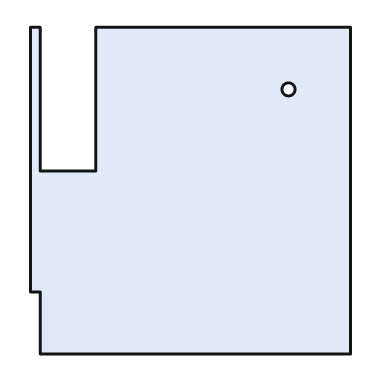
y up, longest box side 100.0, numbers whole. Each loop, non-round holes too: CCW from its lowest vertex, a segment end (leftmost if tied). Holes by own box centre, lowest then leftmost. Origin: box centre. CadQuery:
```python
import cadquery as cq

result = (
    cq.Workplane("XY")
    .moveTo(-46.0, -50.0)
    .lineTo(49.0, -50.0)
    .lineTo(49.0, 50.0)
    .lineTo(-29.0, 50.0)
    .lineTo(-29.0, 6.0)
    .lineTo(-46.0, 6.0)
    .lineTo(-46.0, 50.0)
    .lineTo(-49.0, 50.0)
    .lineTo(-49.0, -31.0)
    .lineTo(-46.0, -31.0)
    .close()
    .moveTo(30.0, 31.0)
    .circle(2.0)
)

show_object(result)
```